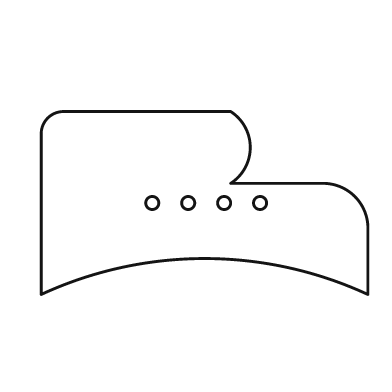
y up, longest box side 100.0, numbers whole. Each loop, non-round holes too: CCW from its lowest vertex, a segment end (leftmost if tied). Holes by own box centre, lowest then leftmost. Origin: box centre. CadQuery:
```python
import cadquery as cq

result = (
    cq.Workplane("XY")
    .moveTo(-50.0, -28.0)
    .threePointArc((0.0, -17.0), (50.0, -28.0))
    .lineTo(50.0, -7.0)
    .threePointArc((46.0, 2.0), (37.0, 6.0))
    .lineTo(8.0, 6.0)
    .threePointArc((14.0, 17.0), (8.0, 28.0))
    .lineTo(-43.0, 28.0)
    .threePointArc((-48.0, 26.0), (-50.0, 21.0))
    .close()
    .moveTo(-16.0, 0.0)
    .circle(2.0)
    .moveTo(-5.0, 0.0)
    .circle(2.0)
    .moveTo(6.0, 0.0)
    .circle(2.0)
    .moveTo(17.0, 0.0)
    .circle(2.0)
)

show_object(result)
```